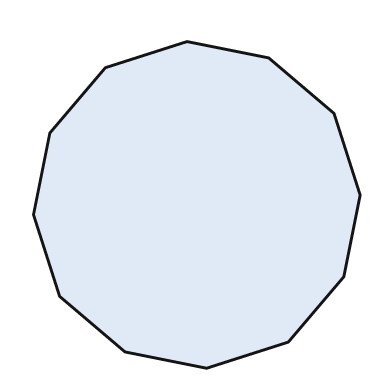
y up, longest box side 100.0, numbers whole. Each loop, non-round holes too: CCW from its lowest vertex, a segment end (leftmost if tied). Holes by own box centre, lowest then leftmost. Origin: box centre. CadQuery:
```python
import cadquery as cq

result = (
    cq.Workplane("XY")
    .moveTo(3.0, -50.0)
    .lineTo(28.0, -42.0)
    .lineTo(45.0, -22.0)
    .lineTo(50.0, 3.0)
    .lineTo(42.0, 28.0)
    .lineTo(22.0, 45.0)
    .lineTo(-3.0, 50.0)
    .lineTo(-28.0, 42.0)
    .lineTo(-45.0, 22.0)
    .lineTo(-50.0, -3.0)
    .lineTo(-42.0, -28.0)
    .lineTo(-22.0, -45.0)
    .close()
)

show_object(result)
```